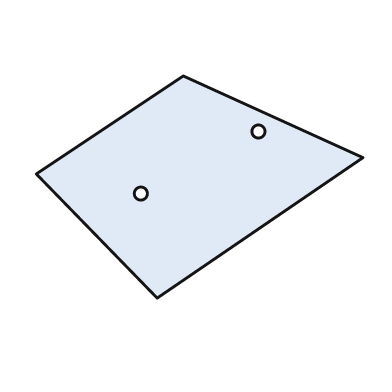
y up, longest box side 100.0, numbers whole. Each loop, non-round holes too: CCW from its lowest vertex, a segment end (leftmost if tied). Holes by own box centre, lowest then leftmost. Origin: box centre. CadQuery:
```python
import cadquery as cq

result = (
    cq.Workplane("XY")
    .moveTo(-13.0, -34.0)
    .lineTo(50.0, 9.0)
    .lineTo(-5.0, 34.0)
    .lineTo(-50.0, 4.0)
    .close()
    .moveTo(-18.0, -2.0)
    .circle(2.0)
    .moveTo(18.0, 17.0)
    .circle(2.0)
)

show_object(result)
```